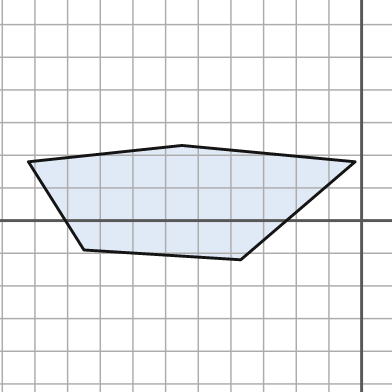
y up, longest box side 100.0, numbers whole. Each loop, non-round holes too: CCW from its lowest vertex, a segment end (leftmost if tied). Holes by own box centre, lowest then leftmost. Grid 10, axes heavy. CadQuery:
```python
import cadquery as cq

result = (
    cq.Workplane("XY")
    .moveTo(-37.0, -12.0)
    .lineTo(-2.0, 18.0)
    .lineTo(-55.0, 23.0)
    .lineTo(-102.0, 18.0)
    .lineTo(-85.0, -9.0)
    .close()
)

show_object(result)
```